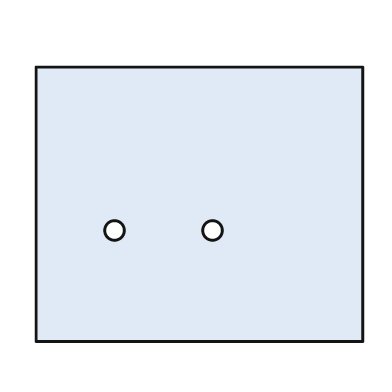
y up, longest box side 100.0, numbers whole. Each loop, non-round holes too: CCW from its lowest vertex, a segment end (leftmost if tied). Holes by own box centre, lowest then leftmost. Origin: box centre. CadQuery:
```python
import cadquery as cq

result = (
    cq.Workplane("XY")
    .moveTo(-50.0, -42.0)
    .lineTo(50.0, -42.0)
    .lineTo(50.0, 42.0)
    .lineTo(-50.0, 42.0)
    .close()
    .moveTo(-26.0, -8.0)
    .circle(3.0)
    .moveTo(4.0, -8.0)
    .circle(3.0)
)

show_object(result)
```